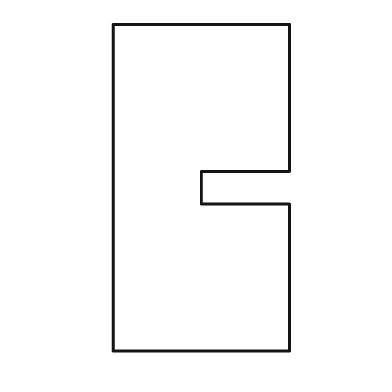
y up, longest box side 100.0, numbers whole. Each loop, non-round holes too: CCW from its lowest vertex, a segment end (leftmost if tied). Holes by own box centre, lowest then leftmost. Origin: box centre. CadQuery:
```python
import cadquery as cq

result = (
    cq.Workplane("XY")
    .moveTo(-27.0, -50.0)
    .lineTo(27.0, -50.0)
    .lineTo(27.0, -5.0)
    .lineTo(0.0, -5.0)
    .lineTo(0.0, 5.0)
    .lineTo(27.0, 5.0)
    .lineTo(27.0, 50.0)
    .lineTo(-27.0, 50.0)
    .close()
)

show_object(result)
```